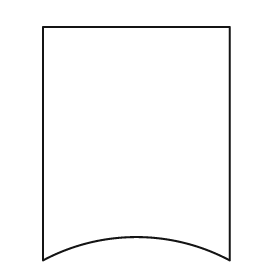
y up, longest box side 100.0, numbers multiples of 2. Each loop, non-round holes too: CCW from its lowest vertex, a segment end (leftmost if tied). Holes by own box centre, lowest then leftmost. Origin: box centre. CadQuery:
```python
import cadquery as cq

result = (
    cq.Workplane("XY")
    .moveTo(-40.0, -50.0)
    .threePointArc((0.0, -40.0), (40.0, -50.0))
    .lineTo(40.0, 50.0)
    .lineTo(-40.0, 50.0)
    .close()
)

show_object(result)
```